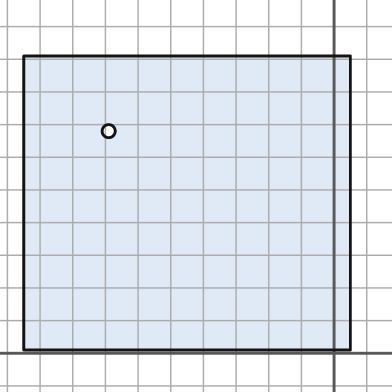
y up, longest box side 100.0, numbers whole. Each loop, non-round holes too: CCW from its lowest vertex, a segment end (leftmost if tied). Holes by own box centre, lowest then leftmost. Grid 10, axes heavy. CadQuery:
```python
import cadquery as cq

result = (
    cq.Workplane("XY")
    .moveTo(-95.0, 1.0)
    .lineTo(5.0, 1.0)
    .lineTo(5.0, 91.0)
    .lineTo(-95.0, 91.0)
    .close()
    .moveTo(-69.0, 68.0)
    .circle(2.0)
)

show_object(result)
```